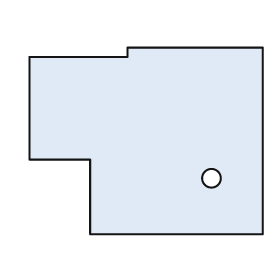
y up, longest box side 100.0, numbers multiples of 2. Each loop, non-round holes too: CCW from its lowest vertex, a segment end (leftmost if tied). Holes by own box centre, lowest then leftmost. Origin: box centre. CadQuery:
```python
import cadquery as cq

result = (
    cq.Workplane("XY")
    .moveTo(-24.0, -40.0)
    .lineTo(50.0, -40.0)
    .lineTo(50.0, 40.0)
    .lineTo(-8.0, 40.0)
    .lineTo(-8.0, 36.0)
    .lineTo(-50.0, 36.0)
    .lineTo(-50.0, -8.0)
    .lineTo(-24.0, -8.0)
    .close()
    .moveTo(28.0, -16.0)
    .circle(4.0)
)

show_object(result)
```